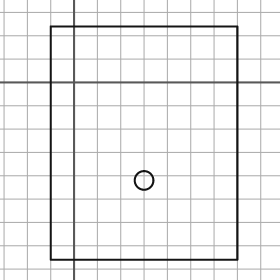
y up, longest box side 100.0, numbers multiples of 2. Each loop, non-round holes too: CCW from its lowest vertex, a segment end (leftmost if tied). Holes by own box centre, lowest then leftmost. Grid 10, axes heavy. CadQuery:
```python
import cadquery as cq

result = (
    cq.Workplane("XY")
    .moveTo(-10.0, -76.0)
    .lineTo(70.0, -76.0)
    .lineTo(70.0, 24.0)
    .lineTo(-10.0, 24.0)
    .close()
    .moveTo(30.0, -42.0)
    .circle(4.0)
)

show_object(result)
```